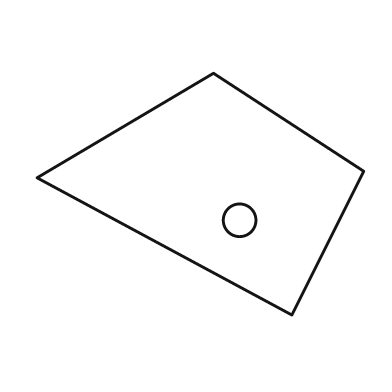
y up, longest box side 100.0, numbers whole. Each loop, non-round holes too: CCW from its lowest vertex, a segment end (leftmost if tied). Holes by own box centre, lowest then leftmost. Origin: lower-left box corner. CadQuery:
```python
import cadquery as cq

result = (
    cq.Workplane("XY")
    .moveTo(78.0, 0.0)
    .lineTo(100.0, 44.0)
    .lineTo(54.0, 74.0)
    .lineTo(0.0, 42.0)
    .close()
    .moveTo(62.0, 29.0)
    .circle(5.0)
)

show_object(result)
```